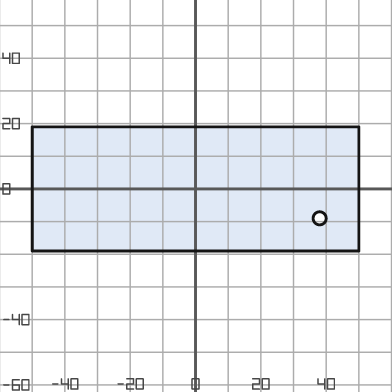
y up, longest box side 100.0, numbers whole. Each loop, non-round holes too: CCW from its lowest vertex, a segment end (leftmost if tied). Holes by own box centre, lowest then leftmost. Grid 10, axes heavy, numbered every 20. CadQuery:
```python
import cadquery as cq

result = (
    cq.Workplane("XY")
    .moveTo(-50.0, -19.0)
    .lineTo(50.0, -19.0)
    .lineTo(50.0, 19.0)
    .lineTo(-50.0, 19.0)
    .close()
    .moveTo(38.0, -9.0)
    .circle(2.0)
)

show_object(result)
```